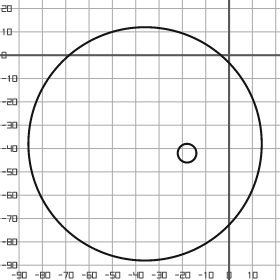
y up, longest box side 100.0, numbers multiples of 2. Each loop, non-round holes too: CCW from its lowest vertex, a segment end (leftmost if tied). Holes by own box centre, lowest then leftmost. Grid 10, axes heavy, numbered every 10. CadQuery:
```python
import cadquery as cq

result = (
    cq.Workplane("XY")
    .moveTo(-36.0, -38.0)
    .circle(50.0)
    .moveTo(-18.0, -42.0)
    .circle(4.0)
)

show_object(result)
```